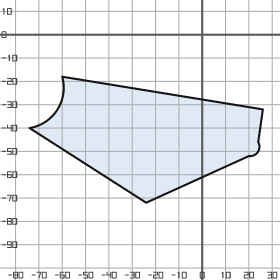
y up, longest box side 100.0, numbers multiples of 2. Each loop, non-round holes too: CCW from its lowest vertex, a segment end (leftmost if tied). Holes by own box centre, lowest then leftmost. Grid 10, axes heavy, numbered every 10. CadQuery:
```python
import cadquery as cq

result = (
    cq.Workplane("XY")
    .moveTo(-24.0, -72.0)
    .lineTo(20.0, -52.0)
    .threePointArc((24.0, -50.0), (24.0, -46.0))
    .lineTo(26.0, -32.0)
    .lineTo(-60.0, -18.0)
    .threePointArc((-62.0, -32.0), (-74.0, -40.0))
    .close()
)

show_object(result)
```